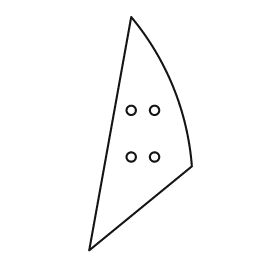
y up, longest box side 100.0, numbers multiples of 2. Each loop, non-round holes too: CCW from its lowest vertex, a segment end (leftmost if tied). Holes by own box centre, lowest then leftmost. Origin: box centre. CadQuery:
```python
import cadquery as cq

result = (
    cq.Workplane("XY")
    .moveTo(-22.0, -50.0)
    .lineTo(22.0, -14.0)
    .threePointArc((14.0, 20.0), (-4.0, 50.0))
    .close()
    .moveTo(-4.0, -10.0)
    .circle(2.0)
    .moveTo(6.0, -10.0)
    .circle(2.0)
    .moveTo(-4.0, 10.0)
    .circle(2.0)
    .moveTo(6.0, 10.0)
    .circle(2.0)
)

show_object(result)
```